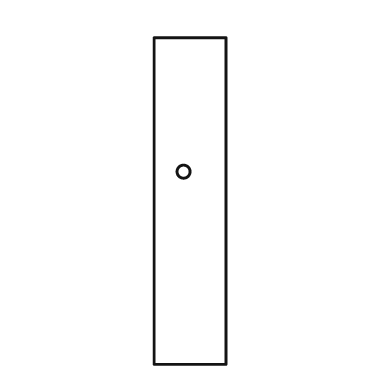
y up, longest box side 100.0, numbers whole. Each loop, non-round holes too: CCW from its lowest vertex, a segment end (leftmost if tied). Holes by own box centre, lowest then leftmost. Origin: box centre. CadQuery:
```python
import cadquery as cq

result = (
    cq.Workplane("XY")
    .moveTo(-11.0, -50.0)
    .lineTo(11.0, -50.0)
    .lineTo(11.0, 50.0)
    .lineTo(-11.0, 50.0)
    .close()
    .moveTo(-2.0, 9.0)
    .circle(2.0)
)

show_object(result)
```